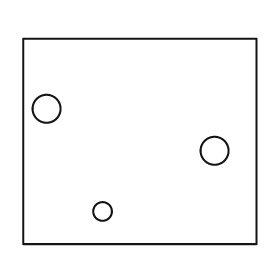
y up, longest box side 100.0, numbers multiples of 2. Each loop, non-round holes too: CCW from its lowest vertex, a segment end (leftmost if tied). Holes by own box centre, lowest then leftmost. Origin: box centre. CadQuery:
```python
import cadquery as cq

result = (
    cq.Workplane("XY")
    .moveTo(-50.0, -44.0)
    .lineTo(50.0, -44.0)
    .lineTo(50.0, 44.0)
    .lineTo(-50.0, 44.0)
    .close()
    .moveTo(-16.0, -30.0)
    .circle(4.0)
    .moveTo(32.0, -4.0)
    .circle(6.0)
    .moveTo(-40.0, 14.0)
    .circle(6.0)
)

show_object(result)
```